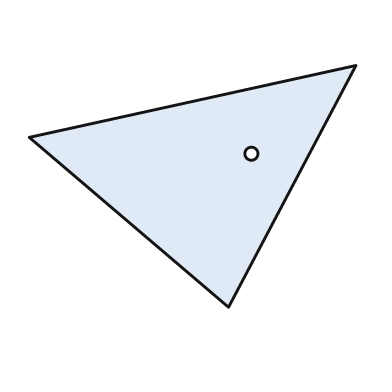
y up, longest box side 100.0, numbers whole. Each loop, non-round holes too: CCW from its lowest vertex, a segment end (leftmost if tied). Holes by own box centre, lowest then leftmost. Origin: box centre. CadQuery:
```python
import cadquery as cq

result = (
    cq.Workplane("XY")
    .moveTo(11.0, -37.0)
    .lineTo(50.0, 37.0)
    .lineTo(-50.0, 15.0)
    .close()
    .moveTo(18.0, 10.0)
    .circle(2.0)
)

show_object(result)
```